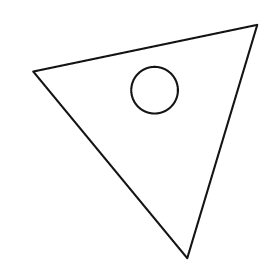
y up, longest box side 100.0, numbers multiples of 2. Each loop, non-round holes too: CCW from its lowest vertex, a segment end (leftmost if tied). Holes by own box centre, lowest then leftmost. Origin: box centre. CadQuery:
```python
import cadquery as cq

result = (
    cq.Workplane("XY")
    .moveTo(18.0, -50.0)
    .lineTo(48.0, 50.0)
    .lineTo(-48.0, 30.0)
    .close()
    .moveTo(4.0, 22.0)
    .circle(10.0)
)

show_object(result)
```